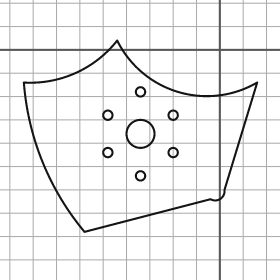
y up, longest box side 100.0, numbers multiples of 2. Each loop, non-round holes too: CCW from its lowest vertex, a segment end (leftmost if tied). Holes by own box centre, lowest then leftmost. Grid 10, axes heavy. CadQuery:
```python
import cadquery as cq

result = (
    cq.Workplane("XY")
    .moveTo(-58.0, -78.0)
    .lineTo(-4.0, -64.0)
    .threePointArc((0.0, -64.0), (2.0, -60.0))
    .lineTo(16.0, -14.0)
    .threePointArc((-18.0, -18.0), (-44.0, 4.0))
    .threePointArc((-62.0, -10.0), (-84.0, -14.0))
    .threePointArc((-76.0, -48.0), (-58.0, -78.0))
    .close()
    .moveTo(-34.0, -54.0)
    .circle(2.0)
    .moveTo(-48.0, -44.0)
    .circle(2.0)
    .moveTo(-20.0, -44.0)
    .circle(2.0)
    .moveTo(-34.0, -36.0)
    .circle(6.0)
    .moveTo(-48.0, -28.0)
    .circle(2.0)
    .moveTo(-20.0, -28.0)
    .circle(2.0)
    .moveTo(-34.0, -18.0)
    .circle(2.0)
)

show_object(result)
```